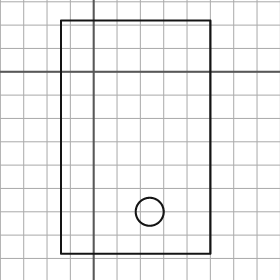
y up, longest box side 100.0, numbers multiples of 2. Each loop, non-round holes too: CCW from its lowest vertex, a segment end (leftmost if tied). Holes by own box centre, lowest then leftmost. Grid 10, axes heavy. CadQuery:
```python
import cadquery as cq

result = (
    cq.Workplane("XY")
    .moveTo(-14.0, -78.0)
    .lineTo(50.0, -78.0)
    .lineTo(50.0, 22.0)
    .lineTo(-14.0, 22.0)
    .close()
    .moveTo(24.0, -60.0)
    .circle(6.0)
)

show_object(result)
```